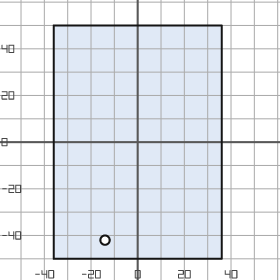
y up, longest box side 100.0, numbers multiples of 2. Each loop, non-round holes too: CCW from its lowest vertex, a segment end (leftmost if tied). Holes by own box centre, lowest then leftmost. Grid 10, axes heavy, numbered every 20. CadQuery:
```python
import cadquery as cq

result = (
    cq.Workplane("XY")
    .moveTo(-36.0, -50.0)
    .lineTo(36.0, -50.0)
    .lineTo(36.0, 50.0)
    .lineTo(-36.0, 50.0)
    .close()
    .moveTo(-14.0, -42.0)
    .circle(2.0)
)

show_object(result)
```